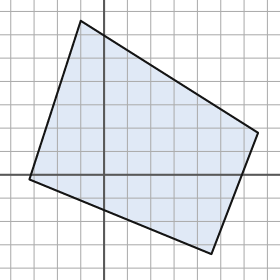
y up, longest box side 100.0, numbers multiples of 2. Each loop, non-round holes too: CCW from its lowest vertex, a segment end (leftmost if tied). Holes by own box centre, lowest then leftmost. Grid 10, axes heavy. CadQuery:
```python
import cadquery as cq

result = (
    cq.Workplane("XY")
    .moveTo(46.0, -34.0)
    .lineTo(66.0, 18.0)
    .lineTo(-10.0, 66.0)
    .lineTo(-32.0, -2.0)
    .close()
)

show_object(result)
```